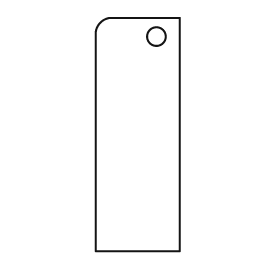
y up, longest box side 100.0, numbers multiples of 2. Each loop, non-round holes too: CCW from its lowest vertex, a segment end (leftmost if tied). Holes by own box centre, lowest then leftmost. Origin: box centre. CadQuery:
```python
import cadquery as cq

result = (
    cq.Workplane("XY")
    .moveTo(-18.0, -50.0)
    .lineTo(18.0, -50.0)
    .lineTo(18.0, 50.0)
    .lineTo(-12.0, 50.0)
    .threePointArc((-16.0, 48.0), (-18.0, 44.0))
    .close()
    .moveTo(8.0, 42.0)
    .circle(4.0)
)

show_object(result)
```